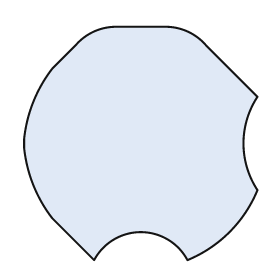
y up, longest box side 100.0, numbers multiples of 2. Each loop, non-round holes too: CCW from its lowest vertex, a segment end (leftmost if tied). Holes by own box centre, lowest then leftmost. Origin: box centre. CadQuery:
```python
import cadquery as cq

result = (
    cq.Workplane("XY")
    .moveTo(-20.0, -50.0)
    .threePointArc((0.0, -38.0), (20.0, -50.0))
    .threePointArc((38.0, -38.0), (50.0, -20.0))
    .threePointArc((44.0, 0.0), (50.0, 20.0))
    .lineTo(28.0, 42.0)
    .threePointArc((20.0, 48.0), (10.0, 50.0))
    .lineTo(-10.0, 50.0)
    .threePointArc((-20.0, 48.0), (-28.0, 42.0))
    .lineTo(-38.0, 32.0)
    .threePointArc((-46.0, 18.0), (-50.0, 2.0))
    .lineTo(-50.0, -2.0)
    .threePointArc((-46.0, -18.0), (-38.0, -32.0))
    .close()
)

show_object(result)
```